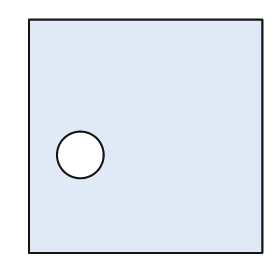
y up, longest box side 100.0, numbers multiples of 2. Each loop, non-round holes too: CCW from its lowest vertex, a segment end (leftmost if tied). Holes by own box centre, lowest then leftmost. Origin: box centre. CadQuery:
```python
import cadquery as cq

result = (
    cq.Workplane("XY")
    .moveTo(-50.0, -50.0)
    .lineTo(50.0, -50.0)
    .lineTo(50.0, 50.0)
    .lineTo(-50.0, 50.0)
    .close()
    .moveTo(-28.0, -8.0)
    .circle(10.0)
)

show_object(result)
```